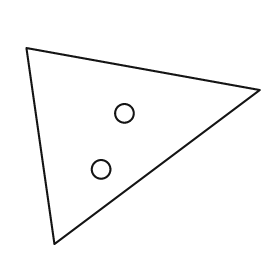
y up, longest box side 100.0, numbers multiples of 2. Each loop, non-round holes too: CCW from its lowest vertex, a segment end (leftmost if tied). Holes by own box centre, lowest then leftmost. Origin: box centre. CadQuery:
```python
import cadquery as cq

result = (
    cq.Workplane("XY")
    .moveTo(-38.0, -42.0)
    .lineTo(50.0, 24.0)
    .lineTo(-50.0, 42.0)
    .close()
    .moveTo(-18.0, -10.0)
    .circle(4.0)
    .moveTo(-8.0, 14.0)
    .circle(4.0)
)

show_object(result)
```